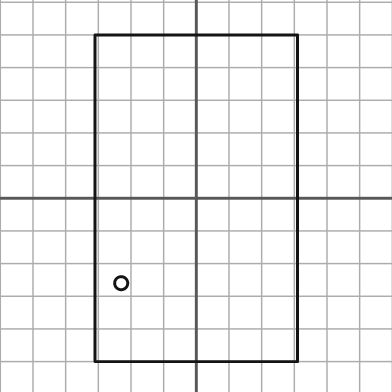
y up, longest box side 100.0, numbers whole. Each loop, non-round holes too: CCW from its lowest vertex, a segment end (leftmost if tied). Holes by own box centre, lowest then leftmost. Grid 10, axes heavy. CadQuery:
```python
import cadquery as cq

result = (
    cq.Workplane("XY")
    .moveTo(-31.0, -50.0)
    .lineTo(31.0, -50.0)
    .lineTo(31.0, 50.0)
    .lineTo(-31.0, 50.0)
    .close()
    .moveTo(-23.0, -26.0)
    .circle(2.0)
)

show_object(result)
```